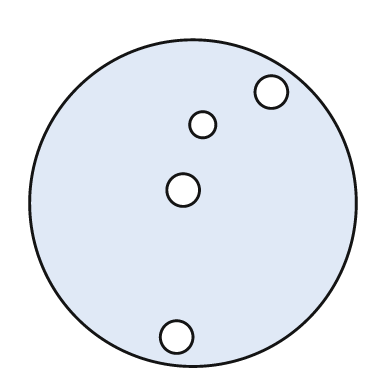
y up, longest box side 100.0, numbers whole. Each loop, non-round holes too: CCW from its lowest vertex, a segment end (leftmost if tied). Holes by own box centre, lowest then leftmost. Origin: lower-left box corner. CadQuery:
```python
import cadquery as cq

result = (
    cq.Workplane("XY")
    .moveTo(50.0, 50.0)
    .circle(50.0)
    .moveTo(45.0, 9.0)
    .circle(5.0)
    .moveTo(47.0, 54.0)
    .circle(5.0)
    .moveTo(53.0, 74.0)
    .circle(4.0)
    .moveTo(74.0, 84.0)
    .circle(5.0)
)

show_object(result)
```